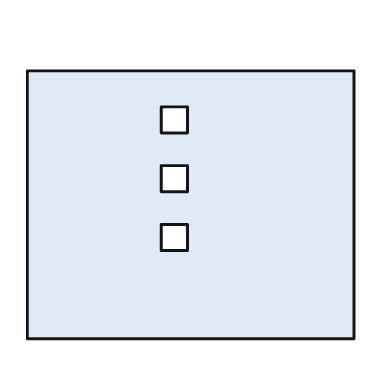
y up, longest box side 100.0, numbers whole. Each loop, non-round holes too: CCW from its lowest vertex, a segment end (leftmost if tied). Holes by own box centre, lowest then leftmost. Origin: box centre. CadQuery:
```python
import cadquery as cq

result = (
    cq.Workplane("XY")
    .moveTo(-50.0, -41.0)
    .lineTo(50.0, -41.0)
    .lineTo(50.0, 41.0)
    .lineTo(-50.0, 41.0)
    .close()
    .moveTo(-9.0, -14.0)
    .lineTo(-1.0, -14.0)
    .lineTo(-1.0, -6.0)
    .lineTo(-9.0, -6.0)
    .close()
    .moveTo(-9.0, 4.0)
    .lineTo(-1.0, 4.0)
    .lineTo(-1.0, 12.0)
    .lineTo(-9.0, 12.0)
    .close()
    .moveTo(-9.0, 22.0)
    .lineTo(-1.0, 22.0)
    .lineTo(-1.0, 30.0)
    .lineTo(-9.0, 30.0)
    .close()
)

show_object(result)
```